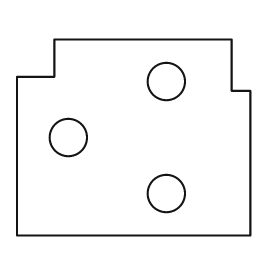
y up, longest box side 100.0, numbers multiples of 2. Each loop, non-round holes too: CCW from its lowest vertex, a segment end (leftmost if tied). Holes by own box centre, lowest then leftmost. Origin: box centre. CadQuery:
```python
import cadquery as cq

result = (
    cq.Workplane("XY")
    .moveTo(-50.0, -42.0)
    .lineTo(50.0, -42.0)
    .lineTo(50.0, 20.0)
    .lineTo(42.0, 20.0)
    .lineTo(42.0, 42.0)
    .lineTo(-34.0, 42.0)
    .lineTo(-34.0, 26.0)
    .lineTo(-50.0, 26.0)
    .close()
    .moveTo(14.0, -24.0)
    .circle(8.0)
    .moveTo(-28.0, 0.0)
    .circle(8.0)
    .moveTo(14.0, 24.0)
    .circle(8.0)
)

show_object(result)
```